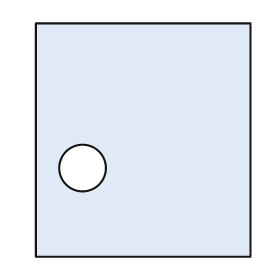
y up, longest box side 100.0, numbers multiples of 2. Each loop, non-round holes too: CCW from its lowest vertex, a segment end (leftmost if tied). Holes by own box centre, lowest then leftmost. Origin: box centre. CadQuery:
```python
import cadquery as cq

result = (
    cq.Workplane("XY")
    .moveTo(-46.0, -50.0)
    .lineTo(46.0, -50.0)
    .lineTo(46.0, 50.0)
    .lineTo(-46.0, 50.0)
    .close()
    .moveTo(-26.0, -12.0)
    .circle(10.0)
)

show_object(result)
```